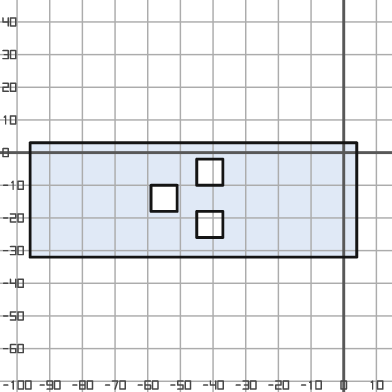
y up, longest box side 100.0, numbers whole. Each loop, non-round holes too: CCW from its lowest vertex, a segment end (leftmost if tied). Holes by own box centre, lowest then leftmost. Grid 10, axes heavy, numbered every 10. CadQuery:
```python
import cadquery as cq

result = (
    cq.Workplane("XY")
    .moveTo(-96.0, -32.0)
    .lineTo(4.0, -32.0)
    .lineTo(4.0, 3.0)
    .lineTo(-96.0, 3.0)
    .close()
    .moveTo(-45.0, -26.0)
    .lineTo(-37.0, -26.0)
    .lineTo(-37.0, -18.0)
    .lineTo(-45.0, -18.0)
    .close()
    .moveTo(-59.0, -18.0)
    .lineTo(-51.0, -18.0)
    .lineTo(-51.0, -10.0)
    .lineTo(-59.0, -10.0)
    .close()
    .moveTo(-45.0, -10.0)
    .lineTo(-37.0, -10.0)
    .lineTo(-37.0, -2.0)
    .lineTo(-45.0, -2.0)
    .close()
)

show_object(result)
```